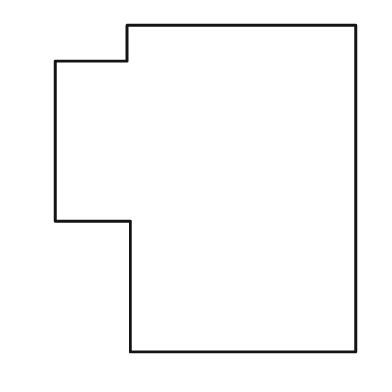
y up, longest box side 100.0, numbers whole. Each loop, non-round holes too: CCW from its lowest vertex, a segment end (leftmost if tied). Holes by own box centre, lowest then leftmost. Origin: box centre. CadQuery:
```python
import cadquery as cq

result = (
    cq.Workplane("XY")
    .moveTo(-23.0, -50.0)
    .lineTo(46.0, -50.0)
    .lineTo(46.0, 50.0)
    .lineTo(-24.0, 50.0)
    .lineTo(-24.0, 39.0)
    .lineTo(-46.0, 39.0)
    .lineTo(-46.0, -10.0)
    .lineTo(-23.0, -10.0)
    .close()
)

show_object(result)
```